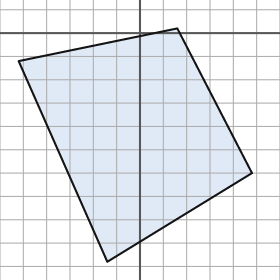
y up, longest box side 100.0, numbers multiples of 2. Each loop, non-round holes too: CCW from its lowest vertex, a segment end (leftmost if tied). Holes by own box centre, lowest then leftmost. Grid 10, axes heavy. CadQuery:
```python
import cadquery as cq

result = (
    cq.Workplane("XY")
    .moveTo(-14.0, -98.0)
    .lineTo(48.0, -60.0)
    .lineTo(16.0, 2.0)
    .lineTo(-52.0, -12.0)
    .close()
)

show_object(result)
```